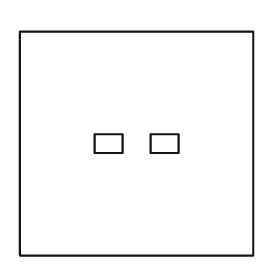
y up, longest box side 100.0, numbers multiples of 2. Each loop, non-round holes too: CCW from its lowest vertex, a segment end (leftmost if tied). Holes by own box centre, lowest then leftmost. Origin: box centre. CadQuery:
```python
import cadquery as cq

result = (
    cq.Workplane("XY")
    .moveTo(-50.0, -48.0)
    .lineTo(50.0, -48.0)
    .lineTo(50.0, 48.0)
    .lineTo(-50.0, 48.0)
    .close()
    .moveTo(-18.0, -4.0)
    .lineTo(-6.0, -4.0)
    .lineTo(-6.0, 4.0)
    .lineTo(-18.0, 4.0)
    .close()
    .moveTo(6.0, -4.0)
    .lineTo(18.0, -4.0)
    .lineTo(18.0, 4.0)
    .lineTo(6.0, 4.0)
    .close()
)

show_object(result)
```